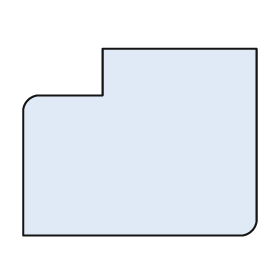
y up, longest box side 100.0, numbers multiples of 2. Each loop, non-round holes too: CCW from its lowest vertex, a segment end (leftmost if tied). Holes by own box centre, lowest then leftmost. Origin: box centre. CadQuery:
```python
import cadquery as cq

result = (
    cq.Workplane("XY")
    .moveTo(-50.0, -40.0)
    .lineTo(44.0, -40.0)
    .threePointArc((48.0, -38.0), (50.0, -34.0))
    .lineTo(50.0, 40.0)
    .lineTo(-16.0, 40.0)
    .lineTo(-16.0, 20.0)
    .lineTo(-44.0, 20.0)
    .threePointArc((-48.0, 18.0), (-50.0, 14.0))
    .close()
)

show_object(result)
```